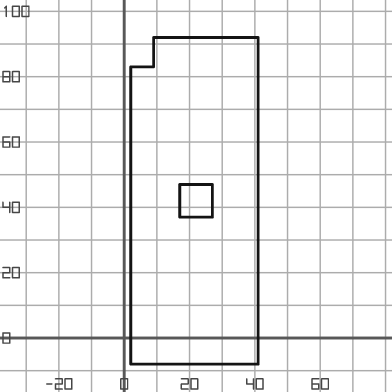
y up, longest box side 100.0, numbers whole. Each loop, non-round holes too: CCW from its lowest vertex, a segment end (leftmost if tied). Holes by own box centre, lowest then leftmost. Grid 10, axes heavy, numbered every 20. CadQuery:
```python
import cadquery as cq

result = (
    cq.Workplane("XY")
    .moveTo(2.0, -8.0)
    .lineTo(41.0, -8.0)
    .lineTo(41.0, 92.0)
    .lineTo(9.0, 92.0)
    .lineTo(9.0, 83.0)
    .lineTo(2.0, 83.0)
    .close()
    .moveTo(17.0, 37.0)
    .lineTo(27.0, 37.0)
    .lineTo(27.0, 47.0)
    .lineTo(17.0, 47.0)
    .close()
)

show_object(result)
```